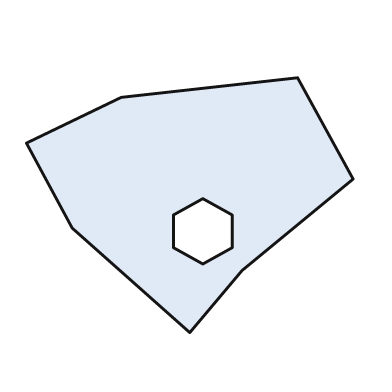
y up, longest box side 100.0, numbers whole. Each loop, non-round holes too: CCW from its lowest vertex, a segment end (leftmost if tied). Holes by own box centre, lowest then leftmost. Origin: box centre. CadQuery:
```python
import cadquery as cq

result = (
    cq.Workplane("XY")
    .moveTo(0.0, -39.0)
    .lineTo(16.0, -20.0)
    .lineTo(50.0, 8.0)
    .lineTo(33.0, 39.0)
    .lineTo(-21.0, 33.0)
    .lineTo(-50.0, 19.0)
    .lineTo(-36.0, -7.0)
    .close()
    .moveTo(4.0, -18.0)
    .lineTo(13.0, -13.0)
    .lineTo(13.0, -3.0)
    .lineTo(4.0, 2.0)
    .lineTo(-5.0, -3.0)
    .lineTo(-5.0, -13.0)
    .close()
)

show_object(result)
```